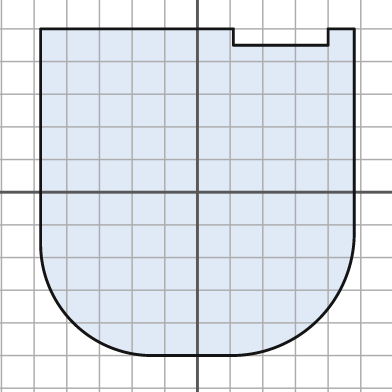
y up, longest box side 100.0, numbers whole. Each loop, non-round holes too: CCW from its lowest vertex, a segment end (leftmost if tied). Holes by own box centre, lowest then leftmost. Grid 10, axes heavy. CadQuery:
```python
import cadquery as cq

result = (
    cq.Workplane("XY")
    .moveTo(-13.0, -50.0)
    .lineTo(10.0, -50.0)
    .threePointArc((37.0, -39.0), (48.0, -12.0))
    .lineTo(48.0, 50.0)
    .lineTo(40.0, 50.0)
    .lineTo(40.0, 45.0)
    .lineTo(11.0, 45.0)
    .lineTo(11.0, 50.0)
    .lineTo(-48.0, 50.0)
    .lineTo(-48.0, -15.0)
    .threePointArc((-38.0, -40.0), (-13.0, -50.0))
    .close()
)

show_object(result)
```